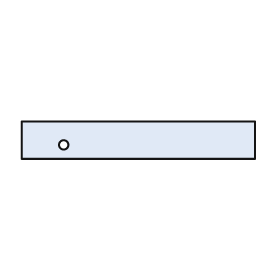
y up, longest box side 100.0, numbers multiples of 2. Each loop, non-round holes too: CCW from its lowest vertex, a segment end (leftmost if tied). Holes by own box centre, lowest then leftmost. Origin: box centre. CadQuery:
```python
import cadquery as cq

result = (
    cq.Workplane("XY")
    .moveTo(-50.0, -8.0)
    .lineTo(50.0, -8.0)
    .lineTo(50.0, 8.0)
    .lineTo(-50.0, 8.0)
    .close()
    .moveTo(-32.0, -2.0)
    .circle(2.0)
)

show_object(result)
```